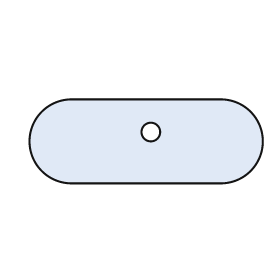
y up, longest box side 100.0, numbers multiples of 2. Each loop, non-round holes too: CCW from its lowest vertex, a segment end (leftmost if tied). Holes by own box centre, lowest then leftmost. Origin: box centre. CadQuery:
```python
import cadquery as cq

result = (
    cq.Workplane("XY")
    .moveTo(-32.0, -18.0)
    .lineTo(32.0, -18.0)
    .threePointArc((50.0, 0.0), (32.0, 18.0))
    .lineTo(-32.0, 18.0)
    .threePointArc((-50.0, 0.0), (-32.0, -18.0))
    .close()
    .moveTo(2.0, 4.0)
    .circle(4.0)
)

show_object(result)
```